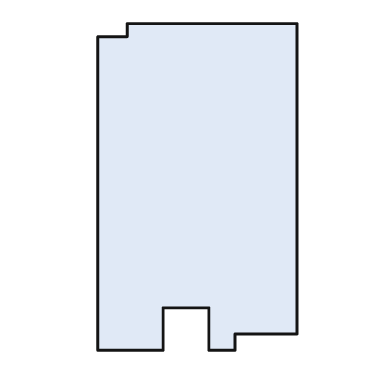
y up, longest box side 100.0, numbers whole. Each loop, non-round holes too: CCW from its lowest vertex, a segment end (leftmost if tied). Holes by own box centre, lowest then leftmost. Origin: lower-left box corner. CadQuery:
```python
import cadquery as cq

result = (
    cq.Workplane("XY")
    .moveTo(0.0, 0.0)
    .lineTo(20.0, 0.0)
    .lineTo(20.0, 13.0)
    .lineTo(34.0, 13.0)
    .lineTo(34.0, 0.0)
    .lineTo(42.0, 0.0)
    .lineTo(42.0, 5.0)
    .lineTo(61.0, 5.0)
    .lineTo(61.0, 100.0)
    .lineTo(9.0, 100.0)
    .lineTo(9.0, 96.0)
    .lineTo(0.0, 96.0)
    .close()
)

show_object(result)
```